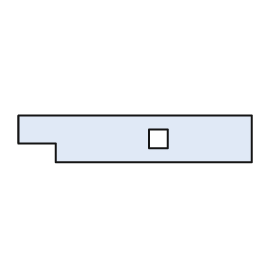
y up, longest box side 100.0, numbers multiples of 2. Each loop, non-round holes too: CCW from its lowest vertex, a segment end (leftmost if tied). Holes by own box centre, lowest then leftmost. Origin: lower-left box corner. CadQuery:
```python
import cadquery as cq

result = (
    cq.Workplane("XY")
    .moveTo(16.0, 0.0)
    .lineTo(100.0, 0.0)
    .lineTo(100.0, 20.0)
    .lineTo(0.0, 20.0)
    .lineTo(0.0, 8.0)
    .lineTo(16.0, 8.0)
    .close()
    .moveTo(56.0, 6.0)
    .lineTo(64.0, 6.0)
    .lineTo(64.0, 14.0)
    .lineTo(56.0, 14.0)
    .close()
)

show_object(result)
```